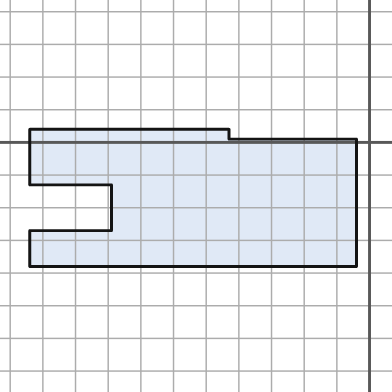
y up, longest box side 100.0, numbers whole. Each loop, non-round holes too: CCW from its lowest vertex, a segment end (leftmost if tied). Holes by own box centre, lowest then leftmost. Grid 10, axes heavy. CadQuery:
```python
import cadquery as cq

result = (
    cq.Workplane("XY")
    .moveTo(-104.0, -38.0)
    .lineTo(-4.0, -38.0)
    .lineTo(-4.0, 1.0)
    .lineTo(-43.0, 1.0)
    .lineTo(-43.0, 4.0)
    .lineTo(-104.0, 4.0)
    .lineTo(-104.0, -13.0)
    .lineTo(-79.0, -13.0)
    .lineTo(-79.0, -27.0)
    .lineTo(-104.0, -27.0)
    .close()
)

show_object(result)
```